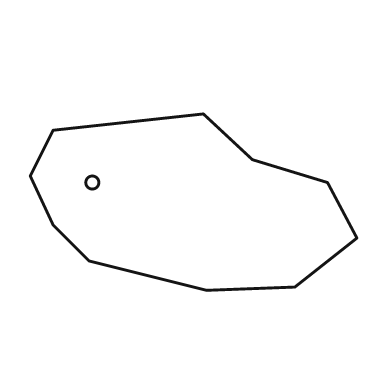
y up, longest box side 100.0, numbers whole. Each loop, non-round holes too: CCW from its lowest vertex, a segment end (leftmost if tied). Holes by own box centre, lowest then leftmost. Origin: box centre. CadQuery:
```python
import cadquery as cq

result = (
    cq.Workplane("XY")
    .moveTo(4.0, -27.0)
    .lineTo(31.0, -26.0)
    .lineTo(50.0, -11.0)
    .lineTo(41.0, 6.0)
    .lineTo(18.0, 13.0)
    .lineTo(3.0, 27.0)
    .lineTo(-43.0, 22.0)
    .lineTo(-50.0, 8.0)
    .lineTo(-43.0, -7.0)
    .lineTo(-32.0, -18.0)
    .close()
    .moveTo(-31.0, 6.0)
    .circle(2.0)
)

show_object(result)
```